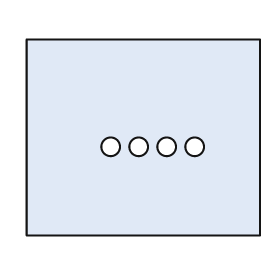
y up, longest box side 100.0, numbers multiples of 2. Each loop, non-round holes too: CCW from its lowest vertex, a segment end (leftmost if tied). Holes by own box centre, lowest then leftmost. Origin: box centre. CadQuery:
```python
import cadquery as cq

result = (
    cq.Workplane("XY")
    .moveTo(-50.0, -42.0)
    .lineTo(50.0, -42.0)
    .lineTo(50.0, 42.0)
    .lineTo(-50.0, 42.0)
    .close()
    .moveTo(-14.0, -4.0)
    .circle(4.0)
    .moveTo(-2.0, -4.0)
    .circle(4.0)
    .moveTo(10.0, -4.0)
    .circle(4.0)
    .moveTo(22.0, -4.0)
    .circle(4.0)
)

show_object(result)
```